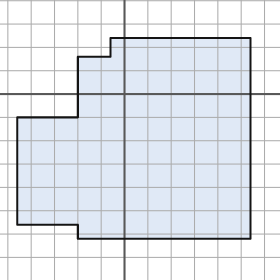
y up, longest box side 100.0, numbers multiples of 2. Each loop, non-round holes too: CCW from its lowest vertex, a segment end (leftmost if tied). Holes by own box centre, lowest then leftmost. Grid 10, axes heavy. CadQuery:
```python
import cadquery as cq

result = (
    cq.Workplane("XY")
    .moveTo(-20.0, -62.0)
    .lineTo(54.0, -62.0)
    .lineTo(54.0, 24.0)
    .lineTo(-6.0, 24.0)
    .lineTo(-6.0, 16.0)
    .lineTo(-20.0, 16.0)
    .lineTo(-20.0, -10.0)
    .lineTo(-46.0, -10.0)
    .lineTo(-46.0, -56.0)
    .lineTo(-20.0, -56.0)
    .close()
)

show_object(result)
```